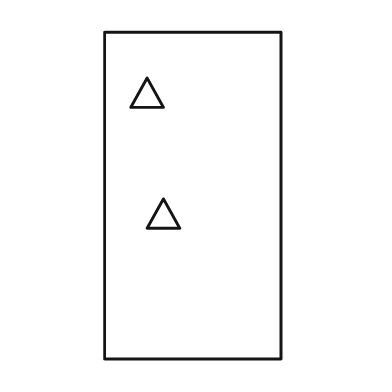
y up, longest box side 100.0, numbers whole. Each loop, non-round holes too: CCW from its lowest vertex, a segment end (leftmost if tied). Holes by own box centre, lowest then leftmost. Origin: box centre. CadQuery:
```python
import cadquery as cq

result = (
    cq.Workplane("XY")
    .moveTo(-27.0, -50.0)
    .lineTo(27.0, -50.0)
    .lineTo(27.0, 50.0)
    .lineTo(-27.0, 50.0)
    .close()
    .moveTo(-14.0, -10.0)
    .lineTo(-4.0, -10.0)
    .lineTo(-9.0, -1.0)
    .close()
    .moveTo(-19.0, 27.0)
    .lineTo(-9.0, 27.0)
    .lineTo(-14.0, 36.0)
    .close()
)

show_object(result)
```